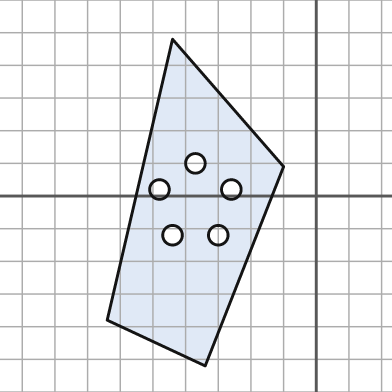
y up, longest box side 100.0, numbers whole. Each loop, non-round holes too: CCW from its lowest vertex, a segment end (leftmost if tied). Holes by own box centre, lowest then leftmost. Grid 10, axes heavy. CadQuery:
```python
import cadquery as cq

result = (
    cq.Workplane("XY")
    .moveTo(-34.0, -52.0)
    .lineTo(-10.0, 9.0)
    .lineTo(-44.0, 48.0)
    .lineTo(-64.0, -38.0)
    .close()
    .moveTo(-44.0, -12.0)
    .circle(3.0)
    .moveTo(-30.0, -12.0)
    .circle(3.0)
    .moveTo(-48.0, 2.0)
    .circle(3.0)
    .moveTo(-26.0, 2.0)
    .circle(3.0)
    .moveTo(-37.0, 10.0)
    .circle(3.0)
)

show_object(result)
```